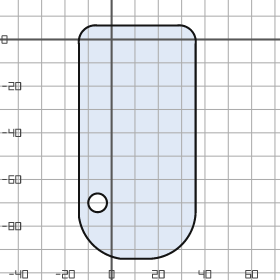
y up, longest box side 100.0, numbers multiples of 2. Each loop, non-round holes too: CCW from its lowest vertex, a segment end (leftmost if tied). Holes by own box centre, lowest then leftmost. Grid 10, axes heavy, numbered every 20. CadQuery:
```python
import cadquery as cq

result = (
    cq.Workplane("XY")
    .moveTo(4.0, -94.0)
    .lineTo(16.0, -94.0)
    .threePointArc((30.0, -88.0), (36.0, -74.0))
    .lineTo(36.0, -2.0)
    .threePointArc((34.0, 4.0), (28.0, 6.0))
    .lineTo(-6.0, 6.0)
    .threePointArc((-12.0, 4.0), (-14.0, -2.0))
    .lineTo(-14.0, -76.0)
    .threePointArc((-8.0, -88.0), (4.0, -94.0))
    .close()
    .moveTo(-6.0, -70.0)
    .circle(4.0)
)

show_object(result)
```